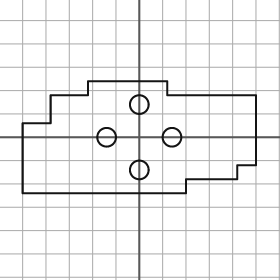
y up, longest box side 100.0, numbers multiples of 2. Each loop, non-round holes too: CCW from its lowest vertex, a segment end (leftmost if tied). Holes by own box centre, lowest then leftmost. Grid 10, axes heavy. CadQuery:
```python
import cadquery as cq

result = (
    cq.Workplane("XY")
    .moveTo(-50.0, -24.0)
    .lineTo(20.0, -24.0)
    .lineTo(20.0, -18.0)
    .lineTo(42.0, -18.0)
    .lineTo(42.0, -12.0)
    .lineTo(50.0, -12.0)
    .lineTo(50.0, 18.0)
    .lineTo(12.0, 18.0)
    .lineTo(12.0, 24.0)
    .lineTo(-22.0, 24.0)
    .lineTo(-22.0, 18.0)
    .lineTo(-38.0, 18.0)
    .lineTo(-38.0, 6.0)
    .lineTo(-50.0, 6.0)
    .close()
    .moveTo(0.0, -14.0)
    .circle(4.0)
    .moveTo(-14.0, 0.0)
    .circle(4.0)
    .moveTo(14.0, 0.0)
    .circle(4.0)
    .moveTo(0.0, 14.0)
    .circle(4.0)
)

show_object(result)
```